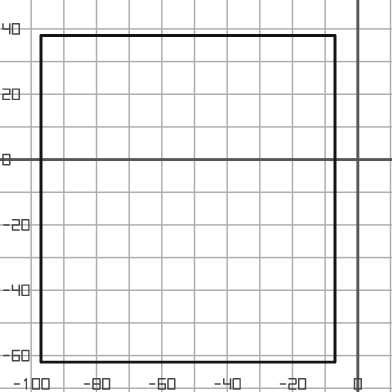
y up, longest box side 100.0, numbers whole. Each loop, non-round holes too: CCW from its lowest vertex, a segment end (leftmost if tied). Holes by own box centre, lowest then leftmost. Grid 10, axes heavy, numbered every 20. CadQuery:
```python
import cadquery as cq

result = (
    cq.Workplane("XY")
    .moveTo(-97.0, -62.0)
    .lineTo(-7.0, -62.0)
    .lineTo(-7.0, 38.0)
    .lineTo(-97.0, 38.0)
    .close()
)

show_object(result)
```